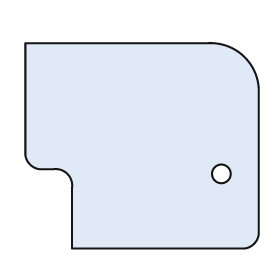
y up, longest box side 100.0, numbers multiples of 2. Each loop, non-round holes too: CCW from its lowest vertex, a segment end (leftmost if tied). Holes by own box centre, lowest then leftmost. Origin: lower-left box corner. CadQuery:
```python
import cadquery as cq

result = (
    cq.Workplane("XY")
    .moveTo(20.0, 0.0)
    .lineTo(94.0, 0.0)
    .threePointArc((98.0, 2.0), (100.0, 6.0))
    .lineTo(100.0, 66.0)
    .threePointArc((94.0, 82.0), (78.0, 88.0))
    .lineTo(0.0, 88.0)
    .lineTo(0.0, 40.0)
    .threePointArc((2.0, 36.0), (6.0, 34.0))
    .lineTo(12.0, 34.0)
    .threePointArc((18.0, 32.0), (20.0, 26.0))
    .close()
    .moveTo(84.0, 32.0)
    .circle(4.0)
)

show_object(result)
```